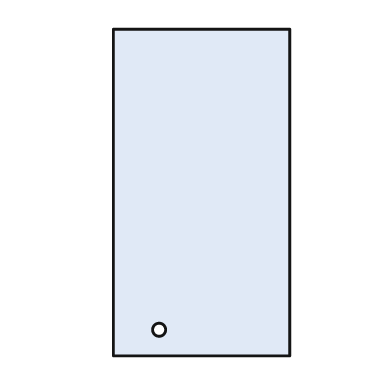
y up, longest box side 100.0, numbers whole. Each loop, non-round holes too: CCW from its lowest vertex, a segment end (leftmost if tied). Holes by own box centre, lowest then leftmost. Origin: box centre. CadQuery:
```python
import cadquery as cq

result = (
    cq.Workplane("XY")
    .moveTo(-27.0, -50.0)
    .lineTo(27.0, -50.0)
    .lineTo(27.0, 50.0)
    .lineTo(-27.0, 50.0)
    .close()
    .moveTo(-13.0, -42.0)
    .circle(2.0)
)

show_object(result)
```